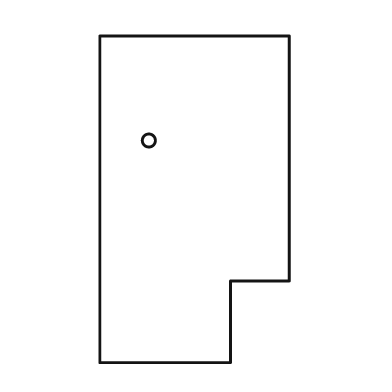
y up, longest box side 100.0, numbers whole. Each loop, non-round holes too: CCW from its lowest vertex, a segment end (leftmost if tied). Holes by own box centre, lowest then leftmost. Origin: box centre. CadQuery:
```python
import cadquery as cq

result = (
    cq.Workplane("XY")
    .moveTo(-29.0, -50.0)
    .lineTo(11.0, -50.0)
    .lineTo(11.0, -25.0)
    .lineTo(29.0, -25.0)
    .lineTo(29.0, 50.0)
    .lineTo(-29.0, 50.0)
    .close()
    .moveTo(-14.0, 18.0)
    .circle(2.0)
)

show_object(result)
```